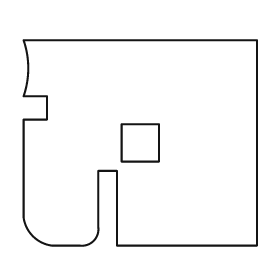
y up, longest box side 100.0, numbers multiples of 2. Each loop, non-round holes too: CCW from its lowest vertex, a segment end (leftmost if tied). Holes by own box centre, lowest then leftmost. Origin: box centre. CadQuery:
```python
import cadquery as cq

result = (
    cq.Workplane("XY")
    .moveTo(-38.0, -44.0)
    .lineTo(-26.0, -44.0)
    .threePointArc((-20.0, -42.0), (-18.0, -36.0))
    .lineTo(-18.0, -12.0)
    .lineTo(-10.0, -12.0)
    .lineTo(-10.0, -44.0)
    .lineTo(50.0, -44.0)
    .lineTo(50.0, 44.0)
    .lineTo(-50.0, 44.0)
    .threePointArc((-48.0, 32.0), (-50.0, 20.0))
    .lineTo(-40.0, 20.0)
    .lineTo(-40.0, 10.0)
    .lineTo(-50.0, 10.0)
    .lineTo(-50.0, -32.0)
    .threePointArc((-46.0, -40.0), (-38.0, -44.0))
    .close()
    .moveTo(-8.0, -8.0)
    .lineTo(8.0, -8.0)
    .lineTo(8.0, 8.0)
    .lineTo(-8.0, 8.0)
    .close()
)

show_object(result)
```